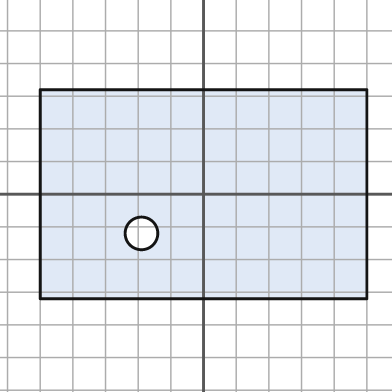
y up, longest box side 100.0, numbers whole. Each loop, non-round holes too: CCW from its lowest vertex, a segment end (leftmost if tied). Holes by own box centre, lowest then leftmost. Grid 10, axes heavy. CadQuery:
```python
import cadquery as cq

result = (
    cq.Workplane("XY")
    .moveTo(-50.0, -32.0)
    .lineTo(50.0, -32.0)
    .lineTo(50.0, 32.0)
    .lineTo(-50.0, 32.0)
    .close()
    .moveTo(-19.0, -12.0)
    .circle(5.0)
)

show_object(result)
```